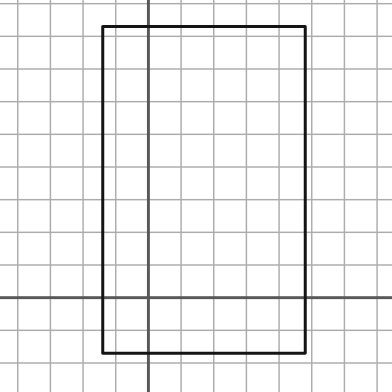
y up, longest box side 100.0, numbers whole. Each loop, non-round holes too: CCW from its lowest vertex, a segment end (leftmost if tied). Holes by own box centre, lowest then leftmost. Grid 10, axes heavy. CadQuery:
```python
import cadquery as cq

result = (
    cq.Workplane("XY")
    .moveTo(-14.0, -17.0)
    .lineTo(48.0, -17.0)
    .lineTo(48.0, 83.0)
    .lineTo(-14.0, 83.0)
    .close()
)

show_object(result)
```